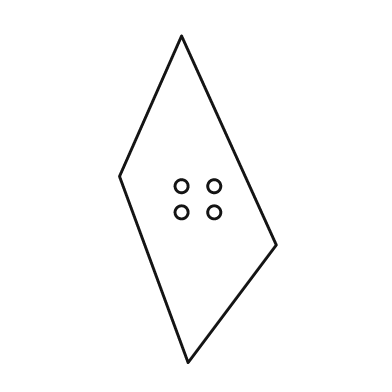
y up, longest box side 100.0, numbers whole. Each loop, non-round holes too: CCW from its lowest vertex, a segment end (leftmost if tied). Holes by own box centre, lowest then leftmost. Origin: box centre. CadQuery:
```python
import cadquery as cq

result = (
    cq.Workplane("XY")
    .moveTo(-3.0, -50.0)
    .lineTo(24.0, -14.0)
    .lineTo(-5.0, 50.0)
    .lineTo(-24.0, 7.0)
    .close()
    .moveTo(-5.0, -4.0)
    .circle(2.0)
    .moveTo(5.0, -4.0)
    .circle(2.0)
    .moveTo(-5.0, 4.0)
    .circle(2.0)
    .moveTo(5.0, 4.0)
    .circle(2.0)
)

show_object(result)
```